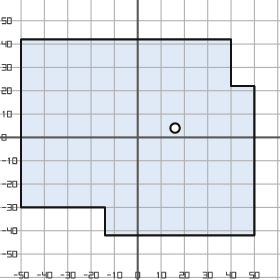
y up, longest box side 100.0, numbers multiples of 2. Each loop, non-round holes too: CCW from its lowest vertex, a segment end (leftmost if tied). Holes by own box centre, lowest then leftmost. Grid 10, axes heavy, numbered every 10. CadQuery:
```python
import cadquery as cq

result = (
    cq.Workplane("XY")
    .moveTo(-14.0, -42.0)
    .lineTo(50.0, -42.0)
    .lineTo(50.0, 22.0)
    .lineTo(40.0, 22.0)
    .lineTo(40.0, 42.0)
    .lineTo(-50.0, 42.0)
    .lineTo(-50.0, -30.0)
    .lineTo(-14.0, -30.0)
    .close()
    .moveTo(16.0, 4.0)
    .circle(2.0)
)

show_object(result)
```